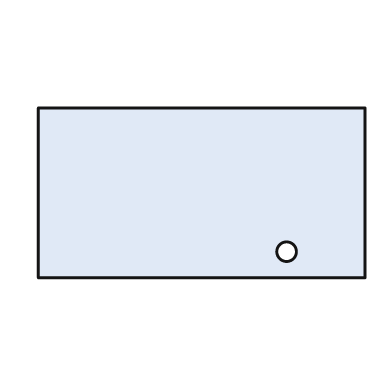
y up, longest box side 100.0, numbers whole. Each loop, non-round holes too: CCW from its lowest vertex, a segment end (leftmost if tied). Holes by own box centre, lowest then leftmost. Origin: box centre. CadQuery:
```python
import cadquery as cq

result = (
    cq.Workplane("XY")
    .moveTo(-50.0, -26.0)
    .lineTo(50.0, -26.0)
    .lineTo(50.0, 26.0)
    .lineTo(-50.0, 26.0)
    .close()
    .moveTo(26.0, -18.0)
    .circle(3.0)
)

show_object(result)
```